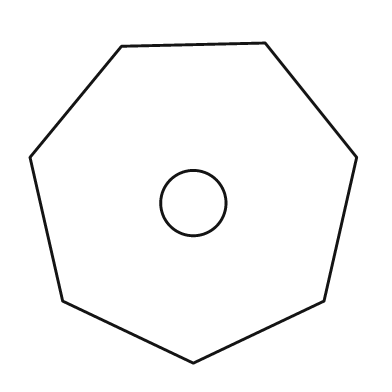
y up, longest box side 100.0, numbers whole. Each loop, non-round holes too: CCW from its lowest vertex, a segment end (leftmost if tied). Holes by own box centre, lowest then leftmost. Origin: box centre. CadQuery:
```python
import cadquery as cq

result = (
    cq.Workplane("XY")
    .moveTo(0.0, -49.0)
    .lineTo(40.0, -30.0)
    .lineTo(50.0, 14.0)
    .lineTo(22.0, 49.0)
    .lineTo(-22.0, 48.0)
    .lineTo(-50.0, 14.0)
    .lineTo(-40.0, -30.0)
    .close()
    .moveTo(0.0, 0.0)
    .circle(10.0)
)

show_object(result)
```